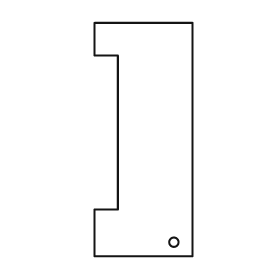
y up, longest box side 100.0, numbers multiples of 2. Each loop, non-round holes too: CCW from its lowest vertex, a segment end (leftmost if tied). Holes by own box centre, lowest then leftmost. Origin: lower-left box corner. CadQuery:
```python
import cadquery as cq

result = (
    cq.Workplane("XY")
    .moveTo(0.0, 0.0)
    .lineTo(42.0, 0.0)
    .lineTo(42.0, 100.0)
    .lineTo(0.0, 100.0)
    .lineTo(0.0, 86.0)
    .lineTo(10.0, 86.0)
    .lineTo(10.0, 20.0)
    .lineTo(0.0, 20.0)
    .close()
    .moveTo(34.0, 6.0)
    .circle(2.0)
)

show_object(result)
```